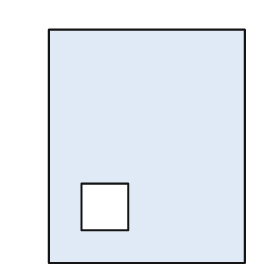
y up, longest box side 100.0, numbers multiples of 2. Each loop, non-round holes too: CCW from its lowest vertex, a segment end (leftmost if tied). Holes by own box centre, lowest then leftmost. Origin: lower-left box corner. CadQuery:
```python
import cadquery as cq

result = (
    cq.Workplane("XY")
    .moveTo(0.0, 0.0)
    .lineTo(84.0, 0.0)
    .lineTo(84.0, 100.0)
    .lineTo(0.0, 100.0)
    .close()
    .moveTo(14.0, 14.0)
    .lineTo(34.0, 14.0)
    .lineTo(34.0, 34.0)
    .lineTo(14.0, 34.0)
    .close()
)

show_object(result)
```